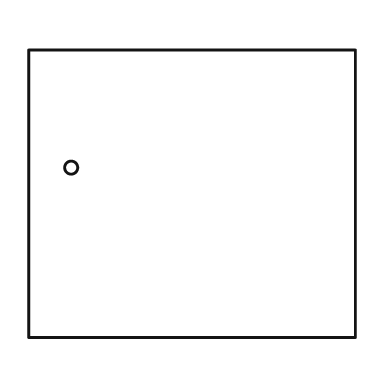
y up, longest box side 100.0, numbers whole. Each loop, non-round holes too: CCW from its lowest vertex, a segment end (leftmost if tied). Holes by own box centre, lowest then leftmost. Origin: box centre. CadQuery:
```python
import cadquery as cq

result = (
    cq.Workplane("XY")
    .moveTo(-50.0, -44.0)
    .lineTo(50.0, -44.0)
    .lineTo(50.0, 44.0)
    .lineTo(-50.0, 44.0)
    .close()
    .moveTo(-37.0, 8.0)
    .circle(2.0)
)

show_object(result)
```